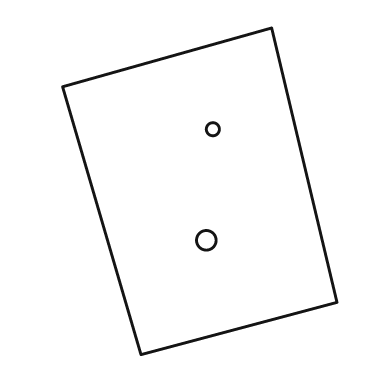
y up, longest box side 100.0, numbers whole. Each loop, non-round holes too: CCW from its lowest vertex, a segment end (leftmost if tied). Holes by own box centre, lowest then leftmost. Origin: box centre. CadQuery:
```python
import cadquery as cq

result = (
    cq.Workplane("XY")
    .moveTo(-18.0, -50.0)
    .lineTo(42.0, -34.0)
    .lineTo(22.0, 50.0)
    .lineTo(-42.0, 32.0)
    .close()
    .moveTo(2.0, -15.0)
    .circle(3.0)
    .moveTo(4.0, 19.0)
    .circle(2.0)
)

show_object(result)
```